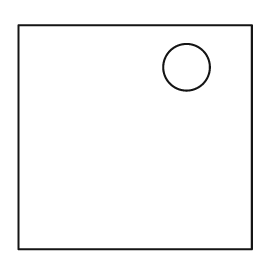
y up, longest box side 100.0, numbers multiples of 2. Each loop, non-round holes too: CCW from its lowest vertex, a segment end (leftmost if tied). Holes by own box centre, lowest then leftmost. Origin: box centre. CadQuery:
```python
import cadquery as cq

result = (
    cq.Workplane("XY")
    .moveTo(-50.0, -48.0)
    .lineTo(50.0, -48.0)
    .lineTo(50.0, 48.0)
    .lineTo(-50.0, 48.0)
    .close()
    .moveTo(22.0, 30.0)
    .circle(10.0)
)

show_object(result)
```